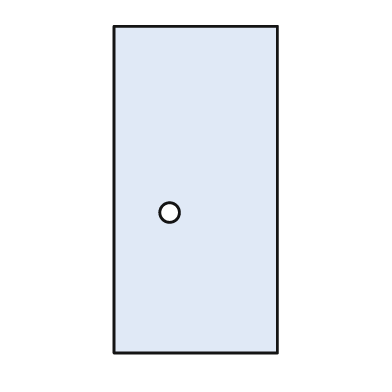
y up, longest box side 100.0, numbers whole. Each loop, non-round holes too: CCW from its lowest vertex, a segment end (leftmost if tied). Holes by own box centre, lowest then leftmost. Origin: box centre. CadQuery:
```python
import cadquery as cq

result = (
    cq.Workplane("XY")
    .moveTo(-25.0, -50.0)
    .lineTo(25.0, -50.0)
    .lineTo(25.0, 50.0)
    .lineTo(-25.0, 50.0)
    .close()
    .moveTo(-8.0, -7.0)
    .circle(3.0)
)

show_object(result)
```